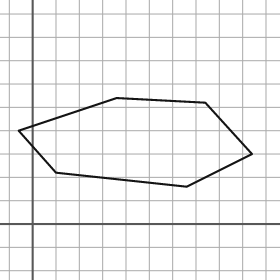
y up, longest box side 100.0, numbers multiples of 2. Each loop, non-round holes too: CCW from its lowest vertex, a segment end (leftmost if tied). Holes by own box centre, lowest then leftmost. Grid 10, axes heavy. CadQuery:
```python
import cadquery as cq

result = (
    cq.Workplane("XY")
    .moveTo(66.0, 16.0)
    .lineTo(94.0, 30.0)
    .lineTo(74.0, 52.0)
    .lineTo(36.0, 54.0)
    .lineTo(-6.0, 40.0)
    .lineTo(10.0, 22.0)
    .close()
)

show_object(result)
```